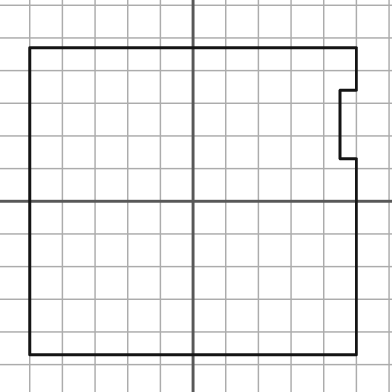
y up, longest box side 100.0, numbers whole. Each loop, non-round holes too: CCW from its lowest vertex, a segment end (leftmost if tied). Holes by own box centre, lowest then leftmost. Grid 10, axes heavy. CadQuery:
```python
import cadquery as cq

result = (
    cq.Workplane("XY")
    .moveTo(-50.0, -47.0)
    .lineTo(50.0, -47.0)
    .lineTo(50.0, 13.0)
    .lineTo(45.0, 13.0)
    .lineTo(45.0, 34.0)
    .lineTo(50.0, 34.0)
    .lineTo(50.0, 47.0)
    .lineTo(-50.0, 47.0)
    .close()
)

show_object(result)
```